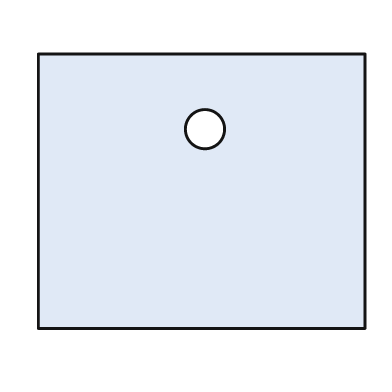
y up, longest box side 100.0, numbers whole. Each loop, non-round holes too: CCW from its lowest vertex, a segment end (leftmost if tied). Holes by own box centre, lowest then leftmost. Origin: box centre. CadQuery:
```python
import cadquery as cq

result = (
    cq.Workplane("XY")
    .moveTo(-50.0, -42.0)
    .lineTo(50.0, -42.0)
    .lineTo(50.0, 42.0)
    .lineTo(-50.0, 42.0)
    .close()
    .moveTo(1.0, 19.0)
    .circle(6.0)
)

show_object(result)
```